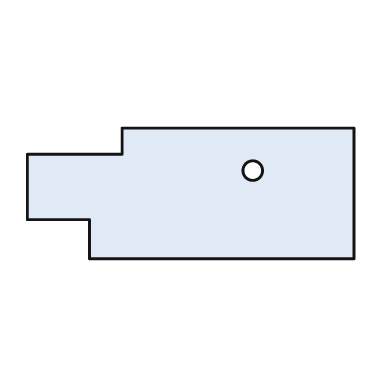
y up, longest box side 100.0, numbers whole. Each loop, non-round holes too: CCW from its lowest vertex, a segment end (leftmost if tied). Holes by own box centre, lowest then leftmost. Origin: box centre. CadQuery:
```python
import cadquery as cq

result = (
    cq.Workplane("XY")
    .moveTo(-31.0, -20.0)
    .lineTo(50.0, -20.0)
    .lineTo(50.0, 20.0)
    .lineTo(-21.0, 20.0)
    .lineTo(-21.0, 12.0)
    .lineTo(-50.0, 12.0)
    .lineTo(-50.0, -8.0)
    .lineTo(-31.0, -8.0)
    .close()
    .moveTo(19.0, 7.0)
    .circle(3.0)
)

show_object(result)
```